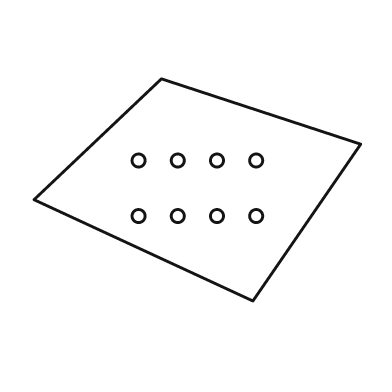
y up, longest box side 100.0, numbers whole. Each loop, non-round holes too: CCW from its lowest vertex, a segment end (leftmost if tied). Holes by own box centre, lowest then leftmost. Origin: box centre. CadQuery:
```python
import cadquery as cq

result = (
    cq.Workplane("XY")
    .moveTo(17.0, -34.0)
    .lineTo(50.0, 14.0)
    .lineTo(-11.0, 34.0)
    .lineTo(-50.0, -3.0)
    .close()
    .moveTo(-18.0, -8.0)
    .circle(2.0)
    .moveTo(-6.0, -8.0)
    .circle(2.0)
    .moveTo(6.0, -8.0)
    .circle(2.0)
    .moveTo(18.0, -8.0)
    .circle(2.0)
    .moveTo(-18.0, 9.0)
    .circle(2.0)
    .moveTo(-6.0, 9.0)
    .circle(2.0)
    .moveTo(6.0, 9.0)
    .circle(2.0)
    .moveTo(18.0, 9.0)
    .circle(2.0)
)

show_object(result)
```